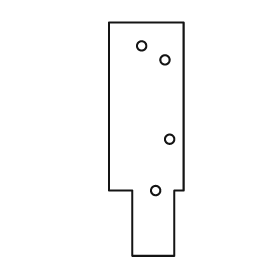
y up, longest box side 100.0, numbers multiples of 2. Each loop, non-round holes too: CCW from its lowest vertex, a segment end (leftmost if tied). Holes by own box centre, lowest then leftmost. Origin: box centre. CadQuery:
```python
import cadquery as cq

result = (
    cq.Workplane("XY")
    .moveTo(-6.0, -50.0)
    .lineTo(12.0, -50.0)
    .lineTo(12.0, -22.0)
    .lineTo(16.0, -22.0)
    .lineTo(16.0, 50.0)
    .lineTo(-16.0, 50.0)
    .lineTo(-16.0, -22.0)
    .lineTo(-6.0, -22.0)
    .close()
    .moveTo(4.0, -22.0)
    .circle(2.0)
    .moveTo(10.0, 0.0)
    .circle(2.0)
    .moveTo(8.0, 34.0)
    .circle(2.0)
    .moveTo(-2.0, 40.0)
    .circle(2.0)
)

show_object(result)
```